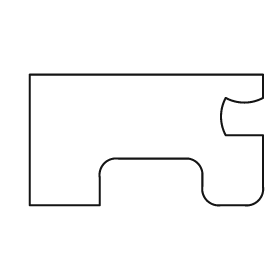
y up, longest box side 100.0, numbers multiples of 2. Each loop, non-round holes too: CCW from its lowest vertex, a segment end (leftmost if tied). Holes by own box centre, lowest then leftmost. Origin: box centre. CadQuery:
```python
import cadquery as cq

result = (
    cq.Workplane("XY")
    .moveTo(-50.0, -28.0)
    .lineTo(-20.0, -28.0)
    .lineTo(-20.0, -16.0)
    .threePointArc((-18.0, -10.0), (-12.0, -8.0))
    .lineTo(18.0, -8.0)
    .threePointArc((22.0, -10.0), (24.0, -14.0))
    .lineTo(24.0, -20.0)
    .threePointArc((26.0, -26.0), (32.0, -28.0))
    .lineTo(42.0, -28.0)
    .threePointArc((48.0, -26.0), (50.0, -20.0))
    .lineTo(50.0, 2.0)
    .lineTo(34.0, 2.0)
    .threePointArc((32.0, 10.0), (34.0, 18.0))
    .threePointArc((42.0, 16.0), (50.0, 18.0))
    .lineTo(50.0, 28.0)
    .lineTo(-50.0, 28.0)
    .close()
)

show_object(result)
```